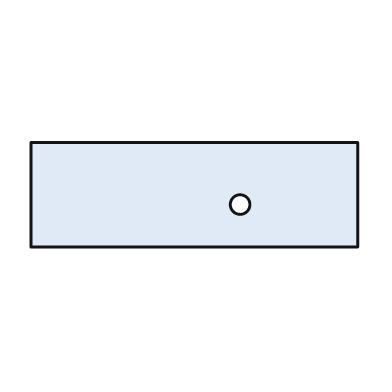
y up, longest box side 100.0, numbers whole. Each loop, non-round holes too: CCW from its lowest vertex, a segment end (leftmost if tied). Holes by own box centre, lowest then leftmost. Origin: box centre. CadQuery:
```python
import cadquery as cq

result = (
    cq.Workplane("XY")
    .moveTo(-50.0, -16.0)
    .lineTo(50.0, -16.0)
    .lineTo(50.0, 16.0)
    .lineTo(-50.0, 16.0)
    .close()
    .moveTo(14.0, -3.0)
    .circle(3.0)
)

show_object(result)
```